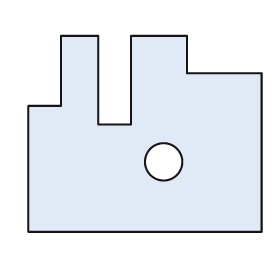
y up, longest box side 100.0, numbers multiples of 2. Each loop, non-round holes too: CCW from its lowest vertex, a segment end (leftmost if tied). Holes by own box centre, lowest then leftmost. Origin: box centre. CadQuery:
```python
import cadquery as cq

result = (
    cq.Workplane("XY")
    .moveTo(-50.0, -42.0)
    .lineTo(50.0, -42.0)
    .lineTo(50.0, 26.0)
    .lineTo(18.0, 26.0)
    .lineTo(18.0, 42.0)
    .lineTo(-6.0, 42.0)
    .lineTo(-6.0, 4.0)
    .lineTo(-20.0, 4.0)
    .lineTo(-20.0, 42.0)
    .lineTo(-36.0, 42.0)
    .lineTo(-36.0, 12.0)
    .lineTo(-50.0, 12.0)
    .close()
    .moveTo(8.0, -12.0)
    .circle(8.0)
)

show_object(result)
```